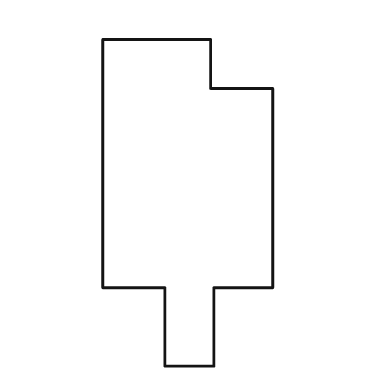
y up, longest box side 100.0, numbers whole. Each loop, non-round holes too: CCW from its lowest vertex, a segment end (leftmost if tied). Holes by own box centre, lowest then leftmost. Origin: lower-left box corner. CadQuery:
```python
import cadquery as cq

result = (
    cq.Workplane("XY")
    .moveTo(19.0, 0.0)
    .lineTo(34.0, 0.0)
    .lineTo(34.0, 24.0)
    .lineTo(52.0, 24.0)
    .lineTo(52.0, 85.0)
    .lineTo(33.0, 85.0)
    .lineTo(33.0, 100.0)
    .lineTo(0.0, 100.0)
    .lineTo(0.0, 24.0)
    .lineTo(19.0, 24.0)
    .close()
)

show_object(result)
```